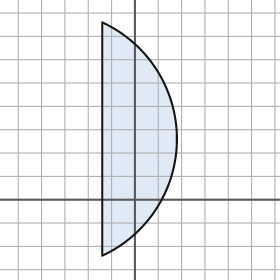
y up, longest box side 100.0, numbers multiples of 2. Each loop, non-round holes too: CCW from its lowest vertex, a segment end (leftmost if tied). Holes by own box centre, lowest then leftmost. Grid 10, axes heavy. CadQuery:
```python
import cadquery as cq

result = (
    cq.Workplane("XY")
    .moveTo(-14.0, -24.0)
    .threePointArc((18.0, 26.0), (-14.0, 76.0))
    .close()
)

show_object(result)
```